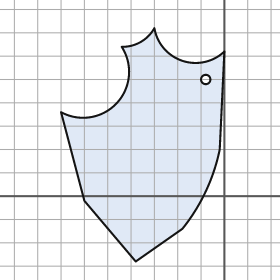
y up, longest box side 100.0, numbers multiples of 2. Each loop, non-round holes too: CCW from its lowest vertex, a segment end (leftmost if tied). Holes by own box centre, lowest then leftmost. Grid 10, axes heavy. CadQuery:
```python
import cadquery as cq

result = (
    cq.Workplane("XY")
    .moveTo(-38.0, -28.0)
    .lineTo(-18.0, -14.0)
    .threePointArc((-8.0, 2.0), (-2.0, 20.0))
    .lineTo(0.0, 62.0)
    .threePointArc((-18.0, 58.0), (-30.0, 72.0))
    .threePointArc((-36.0, 66.0), (-44.0, 64.0))
    .threePointArc((-46.0, 40.0), (-70.0, 36.0))
    .lineTo(-60.0, -2.0)
    .close()
    .moveTo(-8.0, 50.0)
    .circle(2.0)
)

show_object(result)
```